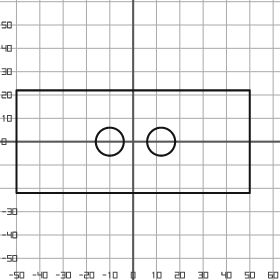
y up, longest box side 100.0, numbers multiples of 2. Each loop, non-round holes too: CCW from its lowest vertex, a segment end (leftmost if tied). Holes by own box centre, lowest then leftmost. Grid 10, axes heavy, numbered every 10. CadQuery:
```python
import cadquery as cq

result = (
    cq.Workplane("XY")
    .moveTo(-50.0, -22.0)
    .lineTo(50.0, -22.0)
    .lineTo(50.0, 22.0)
    .lineTo(-50.0, 22.0)
    .close()
    .moveTo(-10.0, 0.0)
    .circle(6.0)
    .moveTo(12.0, 0.0)
    .circle(6.0)
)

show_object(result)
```